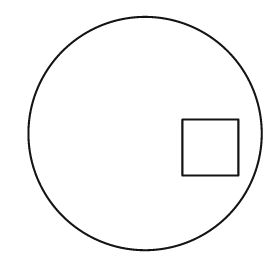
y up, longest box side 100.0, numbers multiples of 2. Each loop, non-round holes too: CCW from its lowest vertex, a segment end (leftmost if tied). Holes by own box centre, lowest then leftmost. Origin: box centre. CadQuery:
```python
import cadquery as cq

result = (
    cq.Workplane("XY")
    .moveTo(0.0, 0.0)
    .circle(50.0)
    .moveTo(16.0, -18.0)
    .lineTo(40.0, -18.0)
    .lineTo(40.0, 6.0)
    .lineTo(16.0, 6.0)
    .close()
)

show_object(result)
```